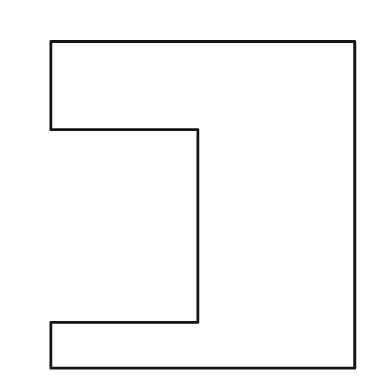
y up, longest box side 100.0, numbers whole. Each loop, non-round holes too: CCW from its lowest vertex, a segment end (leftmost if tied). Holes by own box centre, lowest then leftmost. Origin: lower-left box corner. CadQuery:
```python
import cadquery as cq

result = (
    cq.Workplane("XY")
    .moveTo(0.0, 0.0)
    .lineTo(93.0, 0.0)
    .lineTo(93.0, 100.0)
    .lineTo(0.0, 100.0)
    .lineTo(0.0, 73.0)
    .lineTo(45.0, 73.0)
    .lineTo(45.0, 14.0)
    .lineTo(0.0, 14.0)
    .close()
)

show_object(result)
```